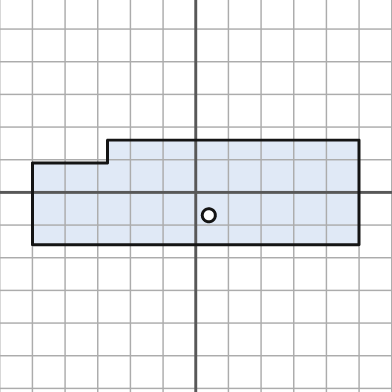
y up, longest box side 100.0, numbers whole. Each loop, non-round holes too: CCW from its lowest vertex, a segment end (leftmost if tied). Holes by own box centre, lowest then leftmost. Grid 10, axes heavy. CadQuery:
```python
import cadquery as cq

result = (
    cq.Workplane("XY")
    .moveTo(-50.0, -16.0)
    .lineTo(50.0, -16.0)
    .lineTo(50.0, 16.0)
    .lineTo(-27.0, 16.0)
    .lineTo(-27.0, 9.0)
    .lineTo(-50.0, 9.0)
    .close()
    .moveTo(4.0, -7.0)
    .circle(2.0)
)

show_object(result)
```